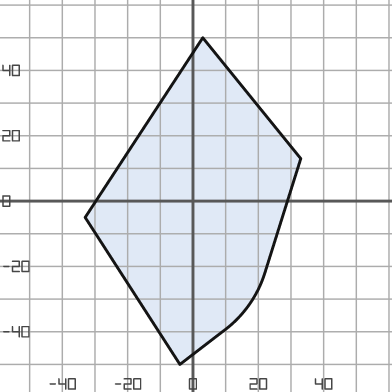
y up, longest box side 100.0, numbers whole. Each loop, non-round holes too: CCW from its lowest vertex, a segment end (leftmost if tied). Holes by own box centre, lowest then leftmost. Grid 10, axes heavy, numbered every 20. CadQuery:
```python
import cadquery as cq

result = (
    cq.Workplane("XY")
    .moveTo(-4.0, -50.0)
    .lineTo(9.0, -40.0)
    .threePointArc((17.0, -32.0), (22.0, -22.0))
    .lineTo(33.0, 13.0)
    .lineTo(3.0, 50.0)
    .lineTo(-33.0, -5.0)
    .close()
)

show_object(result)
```